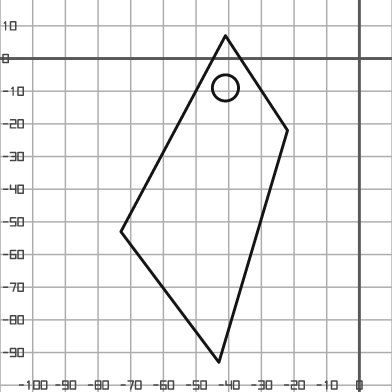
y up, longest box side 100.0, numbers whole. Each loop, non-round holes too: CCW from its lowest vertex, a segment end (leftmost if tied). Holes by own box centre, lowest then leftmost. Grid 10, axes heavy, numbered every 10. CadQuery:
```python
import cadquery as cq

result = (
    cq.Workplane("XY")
    .moveTo(-43.0, -93.0)
    .lineTo(-22.0, -22.0)
    .lineTo(-41.0, 7.0)
    .lineTo(-73.0, -53.0)
    .close()
    .moveTo(-41.0, -9.0)
    .circle(4.0)
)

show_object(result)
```